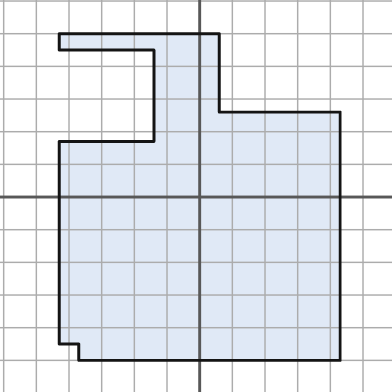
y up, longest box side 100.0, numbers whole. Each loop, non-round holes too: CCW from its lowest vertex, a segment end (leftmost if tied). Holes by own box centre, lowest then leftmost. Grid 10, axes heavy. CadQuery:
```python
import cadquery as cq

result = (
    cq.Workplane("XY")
    .moveTo(-37.0, -50.0)
    .lineTo(43.0, -50.0)
    .lineTo(43.0, 26.0)
    .lineTo(6.0, 26.0)
    .lineTo(6.0, 50.0)
    .lineTo(-43.0, 50.0)
    .lineTo(-43.0, 45.0)
    .lineTo(-14.0, 45.0)
    .lineTo(-14.0, 17.0)
    .lineTo(-43.0, 17.0)
    .lineTo(-43.0, -45.0)
    .lineTo(-37.0, -45.0)
    .close()
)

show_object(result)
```